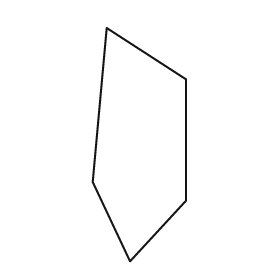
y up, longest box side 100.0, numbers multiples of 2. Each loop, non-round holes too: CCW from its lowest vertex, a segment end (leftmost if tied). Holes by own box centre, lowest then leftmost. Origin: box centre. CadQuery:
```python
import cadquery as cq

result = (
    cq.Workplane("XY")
    .moveTo(-4.0, -50.0)
    .lineTo(20.0, -24.0)
    .lineTo(20.0, 28.0)
    .lineTo(-14.0, 50.0)
    .lineTo(-20.0, -16.0)
    .close()
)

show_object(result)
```